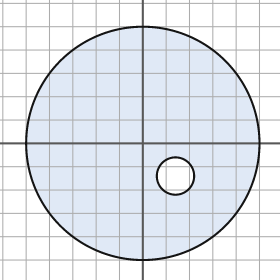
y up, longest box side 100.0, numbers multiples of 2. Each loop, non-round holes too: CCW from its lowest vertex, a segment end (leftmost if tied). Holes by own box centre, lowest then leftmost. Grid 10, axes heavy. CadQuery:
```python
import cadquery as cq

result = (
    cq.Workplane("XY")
    .moveTo(0.0, 0.0)
    .circle(50.0)
    .moveTo(14.0, -14.0)
    .circle(8.0)
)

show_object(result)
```